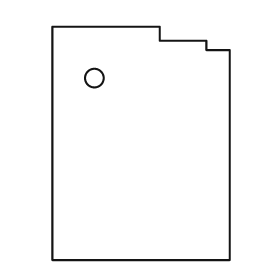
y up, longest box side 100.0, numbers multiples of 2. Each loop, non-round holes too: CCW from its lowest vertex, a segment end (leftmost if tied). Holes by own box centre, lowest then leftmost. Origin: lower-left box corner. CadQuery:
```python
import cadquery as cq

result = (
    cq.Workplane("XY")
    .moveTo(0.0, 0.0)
    .lineTo(76.0, 0.0)
    .lineTo(76.0, 90.0)
    .lineTo(66.0, 90.0)
    .lineTo(66.0, 94.0)
    .lineTo(46.0, 94.0)
    .lineTo(46.0, 100.0)
    .lineTo(0.0, 100.0)
    .close()
    .moveTo(18.0, 78.0)
    .circle(4.0)
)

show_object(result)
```